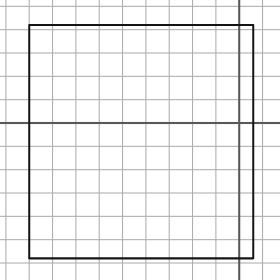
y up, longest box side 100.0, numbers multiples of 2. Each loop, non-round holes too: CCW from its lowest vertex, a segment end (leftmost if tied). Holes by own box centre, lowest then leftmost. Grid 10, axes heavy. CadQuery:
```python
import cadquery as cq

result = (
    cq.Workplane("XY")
    .moveTo(-90.0, -58.0)
    .lineTo(6.0, -58.0)
    .lineTo(6.0, 42.0)
    .lineTo(-90.0, 42.0)
    .close()
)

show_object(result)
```